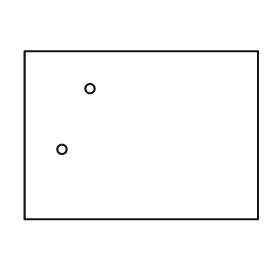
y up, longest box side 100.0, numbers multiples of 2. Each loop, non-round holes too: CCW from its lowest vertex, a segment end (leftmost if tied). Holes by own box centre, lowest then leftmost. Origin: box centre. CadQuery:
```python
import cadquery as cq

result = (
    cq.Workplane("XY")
    .moveTo(-50.0, -36.0)
    .lineTo(50.0, -36.0)
    .lineTo(50.0, 36.0)
    .lineTo(-50.0, 36.0)
    .close()
    .moveTo(-34.0, -6.0)
    .circle(2.0)
    .moveTo(-22.0, 20.0)
    .circle(2.0)
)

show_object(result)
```